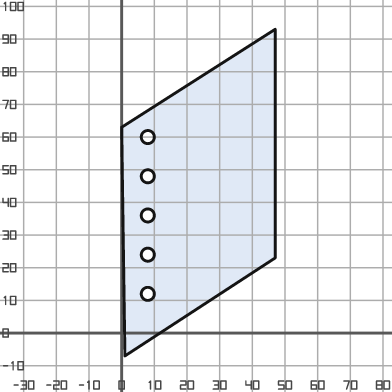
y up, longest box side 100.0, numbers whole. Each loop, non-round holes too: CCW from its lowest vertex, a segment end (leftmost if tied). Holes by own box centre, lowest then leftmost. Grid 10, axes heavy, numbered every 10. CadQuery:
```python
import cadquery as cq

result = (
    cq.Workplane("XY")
    .moveTo(1.0, -7.0)
    .lineTo(47.0, 23.0)
    .lineTo(47.0, 93.0)
    .lineTo(0.0, 63.0)
    .close()
    .moveTo(8.0, 12.0)
    .circle(2.0)
    .moveTo(8.0, 24.0)
    .circle(2.0)
    .moveTo(8.0, 36.0)
    .circle(2.0)
    .moveTo(8.0, 48.0)
    .circle(2.0)
    .moveTo(8.0, 60.0)
    .circle(2.0)
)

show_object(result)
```